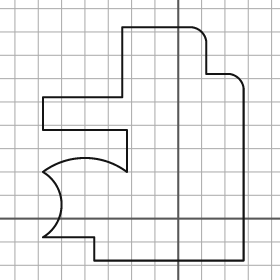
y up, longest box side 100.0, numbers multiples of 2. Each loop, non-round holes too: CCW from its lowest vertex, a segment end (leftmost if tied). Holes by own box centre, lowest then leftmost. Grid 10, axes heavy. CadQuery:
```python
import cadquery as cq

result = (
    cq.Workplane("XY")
    .moveTo(-36.0, -18.0)
    .lineTo(28.0, -18.0)
    .lineTo(28.0, 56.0)
    .threePointArc((26.0, 60.0), (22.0, 62.0))
    .lineTo(12.0, 62.0)
    .lineTo(12.0, 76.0)
    .threePointArc((10.0, 80.0), (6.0, 82.0))
    .lineTo(-24.0, 82.0)
    .lineTo(-24.0, 52.0)
    .lineTo(-58.0, 52.0)
    .lineTo(-58.0, 38.0)
    .lineTo(-22.0, 38.0)
    .lineTo(-22.0, 20.0)
    .threePointArc((-40.0, 26.0), (-58.0, 20.0))
    .threePointArc((-50.0, 6.0), (-58.0, -8.0))
    .lineTo(-36.0, -8.0)
    .close()
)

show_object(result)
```